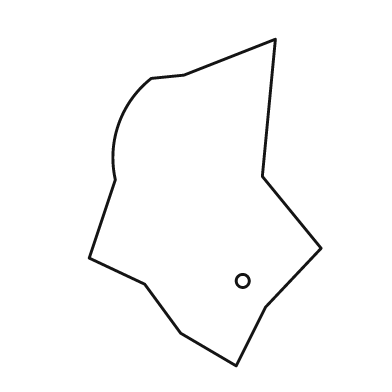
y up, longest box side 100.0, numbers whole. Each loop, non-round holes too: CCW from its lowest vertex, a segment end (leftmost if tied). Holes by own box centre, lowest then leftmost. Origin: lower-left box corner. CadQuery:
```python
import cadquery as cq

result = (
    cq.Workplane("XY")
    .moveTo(45.0, 0.0)
    .lineTo(54.0, 18.0)
    .lineTo(71.0, 36.0)
    .lineTo(53.0, 58.0)
    .lineTo(57.0, 100.0)
    .lineTo(29.0, 89.0)
    .lineTo(19.0, 88.0)
    .threePointArc((9.0, 74.0), (8.0, 57.0))
    .lineTo(0.0, 33.0)
    .lineTo(17.0, 25.0)
    .lineTo(28.0, 10.0)
    .close()
    .moveTo(47.0, 26.0)
    .circle(2.0)
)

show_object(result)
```